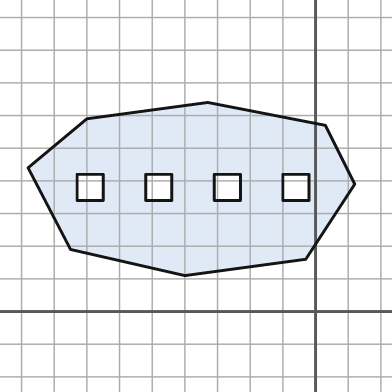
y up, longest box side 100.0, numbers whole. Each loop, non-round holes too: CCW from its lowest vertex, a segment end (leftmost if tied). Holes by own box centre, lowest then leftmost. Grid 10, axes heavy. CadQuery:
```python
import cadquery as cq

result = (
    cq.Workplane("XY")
    .moveTo(-40.0, 11.0)
    .lineTo(-3.0, 16.0)
    .lineTo(12.0, 39.0)
    .lineTo(3.0, 57.0)
    .lineTo(-33.0, 64.0)
    .lineTo(-70.0, 59.0)
    .lineTo(-88.0, 44.0)
    .lineTo(-75.0, 19.0)
    .close()
    .moveTo(-73.0, 34.0)
    .lineTo(-65.0, 34.0)
    .lineTo(-65.0, 42.0)
    .lineTo(-73.0, 42.0)
    .close()
    .moveTo(-52.0, 34.0)
    .lineTo(-44.0, 34.0)
    .lineTo(-44.0, 42.0)
    .lineTo(-52.0, 42.0)
    .close()
    .moveTo(-31.0, 34.0)
    .lineTo(-23.0, 34.0)
    .lineTo(-23.0, 42.0)
    .lineTo(-31.0, 42.0)
    .close()
    .moveTo(-10.0, 34.0)
    .lineTo(-2.0, 34.0)
    .lineTo(-2.0, 42.0)
    .lineTo(-10.0, 42.0)
    .close()
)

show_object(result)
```